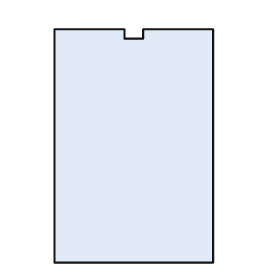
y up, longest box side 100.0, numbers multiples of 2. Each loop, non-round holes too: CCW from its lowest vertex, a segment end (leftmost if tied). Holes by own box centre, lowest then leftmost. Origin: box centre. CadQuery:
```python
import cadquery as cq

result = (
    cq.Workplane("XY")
    .moveTo(-34.0, -50.0)
    .lineTo(34.0, -50.0)
    .lineTo(34.0, 50.0)
    .lineTo(4.0, 50.0)
    .lineTo(4.0, 46.0)
    .lineTo(-4.0, 46.0)
    .lineTo(-4.0, 50.0)
    .lineTo(-34.0, 50.0)
    .close()
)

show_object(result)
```